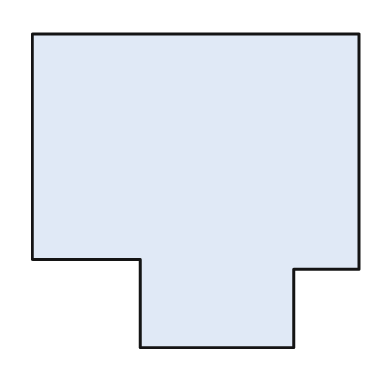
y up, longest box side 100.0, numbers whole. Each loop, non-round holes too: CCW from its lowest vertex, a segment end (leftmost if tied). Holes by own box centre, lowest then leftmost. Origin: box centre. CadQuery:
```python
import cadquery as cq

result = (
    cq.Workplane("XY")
    .moveTo(-17.0, -48.0)
    .lineTo(30.0, -48.0)
    .lineTo(30.0, -24.0)
    .lineTo(50.0, -24.0)
    .lineTo(50.0, 48.0)
    .lineTo(-50.0, 48.0)
    .lineTo(-50.0, -21.0)
    .lineTo(-17.0, -21.0)
    .close()
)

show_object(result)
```